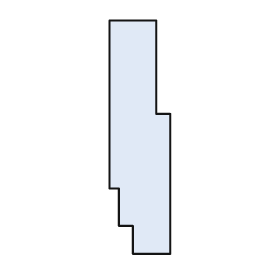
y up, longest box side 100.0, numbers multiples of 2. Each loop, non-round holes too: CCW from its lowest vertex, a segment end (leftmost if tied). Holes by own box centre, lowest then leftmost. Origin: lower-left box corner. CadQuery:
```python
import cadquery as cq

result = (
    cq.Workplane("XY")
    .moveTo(10.0, 0.0)
    .lineTo(26.0, 0.0)
    .lineTo(26.0, 60.0)
    .lineTo(20.0, 60.0)
    .lineTo(20.0, 100.0)
    .lineTo(0.0, 100.0)
    .lineTo(0.0, 28.0)
    .lineTo(4.0, 28.0)
    .lineTo(4.0, 12.0)
    .lineTo(10.0, 12.0)
    .close()
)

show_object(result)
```